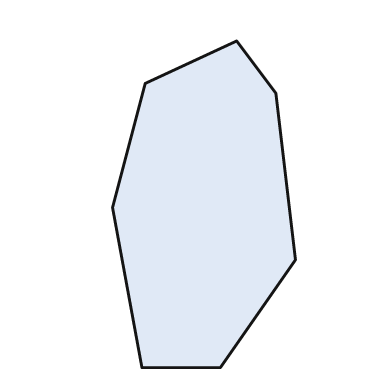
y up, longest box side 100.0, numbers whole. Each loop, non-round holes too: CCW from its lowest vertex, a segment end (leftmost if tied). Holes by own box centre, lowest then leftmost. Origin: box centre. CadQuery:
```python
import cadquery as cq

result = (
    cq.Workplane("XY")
    .moveTo(-19.0, -50.0)
    .lineTo(5.0, -50.0)
    .lineTo(28.0, -17.0)
    .lineTo(22.0, 34.0)
    .lineTo(10.0, 50.0)
    .lineTo(-18.0, 37.0)
    .lineTo(-28.0, -1.0)
    .close()
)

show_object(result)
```